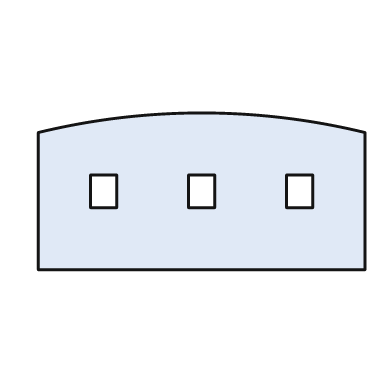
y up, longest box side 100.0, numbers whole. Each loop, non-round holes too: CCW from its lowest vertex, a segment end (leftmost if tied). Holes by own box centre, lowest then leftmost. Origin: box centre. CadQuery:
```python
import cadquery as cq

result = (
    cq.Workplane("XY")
    .moveTo(-50.0, -24.0)
    .lineTo(50.0, -24.0)
    .lineTo(50.0, 18.0)
    .threePointArc((0.0, 24.0), (-50.0, 18.0))
    .close()
    .moveTo(-34.0, -5.0)
    .lineTo(-26.0, -5.0)
    .lineTo(-26.0, 5.0)
    .lineTo(-34.0, 5.0)
    .close()
    .moveTo(-4.0, -5.0)
    .lineTo(4.0, -5.0)
    .lineTo(4.0, 5.0)
    .lineTo(-4.0, 5.0)
    .close()
    .moveTo(26.0, -5.0)
    .lineTo(34.0, -5.0)
    .lineTo(34.0, 5.0)
    .lineTo(26.0, 5.0)
    .close()
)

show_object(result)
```